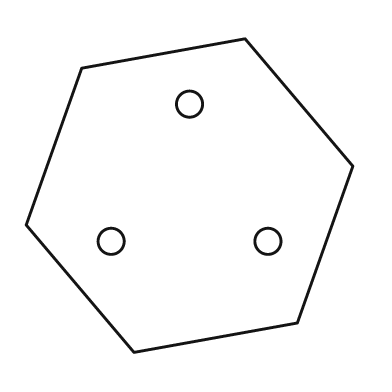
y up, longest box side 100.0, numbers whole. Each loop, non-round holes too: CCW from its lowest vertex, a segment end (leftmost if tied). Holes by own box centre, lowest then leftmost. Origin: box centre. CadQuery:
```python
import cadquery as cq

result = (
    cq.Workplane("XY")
    .moveTo(-17.0, -48.0)
    .lineTo(33.0, -39.0)
    .lineTo(50.0, 9.0)
    .lineTo(17.0, 48.0)
    .lineTo(-33.0, 39.0)
    .lineTo(-50.0, -9.0)
    .close()
    .moveTo(-24.0, -14.0)
    .circle(4.0)
    .moveTo(24.0, -14.0)
    .circle(4.0)
    .moveTo(0.0, 28.0)
    .circle(4.0)
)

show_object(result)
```